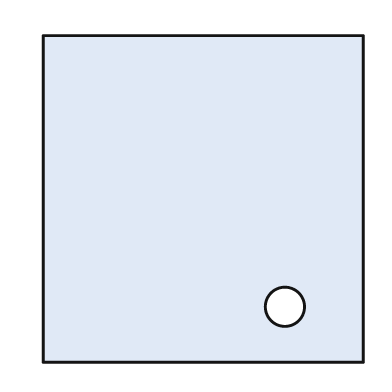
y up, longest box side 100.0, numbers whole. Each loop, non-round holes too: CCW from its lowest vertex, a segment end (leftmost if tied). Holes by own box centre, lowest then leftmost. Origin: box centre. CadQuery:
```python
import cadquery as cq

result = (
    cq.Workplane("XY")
    .moveTo(-49.0, -50.0)
    .lineTo(49.0, -50.0)
    .lineTo(49.0, 50.0)
    .lineTo(-49.0, 50.0)
    .close()
    .moveTo(25.0, -33.0)
    .circle(6.0)
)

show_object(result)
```